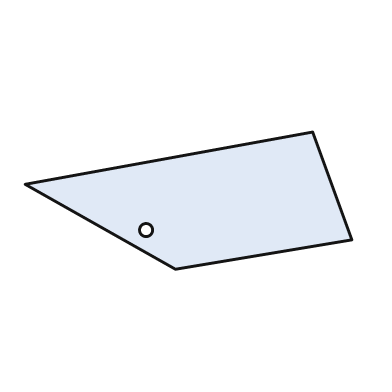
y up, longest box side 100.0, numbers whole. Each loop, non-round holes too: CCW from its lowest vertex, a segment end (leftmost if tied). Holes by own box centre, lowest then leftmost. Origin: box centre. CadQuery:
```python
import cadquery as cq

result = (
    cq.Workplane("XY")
    .moveTo(-4.0, -21.0)
    .lineTo(50.0, -12.0)
    .lineTo(38.0, 21.0)
    .lineTo(-50.0, 5.0)
    .close()
    .moveTo(-13.0, -9.0)
    .circle(2.0)
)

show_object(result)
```